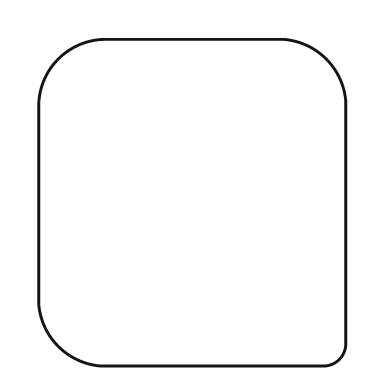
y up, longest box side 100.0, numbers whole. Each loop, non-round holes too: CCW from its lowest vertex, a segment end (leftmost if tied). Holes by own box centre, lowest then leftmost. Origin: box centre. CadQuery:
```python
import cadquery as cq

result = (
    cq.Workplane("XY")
    .moveTo(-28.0, -50.0)
    .lineTo(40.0, -50.0)
    .threePointArc((45.0, -48.0), (47.0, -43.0))
    .lineTo(47.0, 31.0)
    .threePointArc((41.0, 44.0), (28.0, 50.0))
    .lineTo(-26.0, 50.0)
    .threePointArc((-41.0, 44.0), (-47.0, 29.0))
    .lineTo(-47.0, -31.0)
    .threePointArc((-41.0, -44.0), (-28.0, -50.0))
    .close()
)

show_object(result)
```